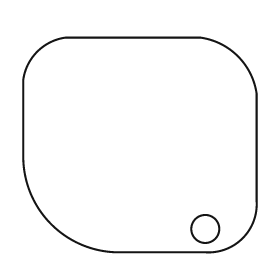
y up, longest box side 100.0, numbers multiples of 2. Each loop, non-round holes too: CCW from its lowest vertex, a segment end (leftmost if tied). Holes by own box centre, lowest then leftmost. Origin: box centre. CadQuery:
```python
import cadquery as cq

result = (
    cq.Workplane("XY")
    .moveTo(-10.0, -46.0)
    .lineTo(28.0, -46.0)
    .threePointArc((44.0, -40.0), (50.0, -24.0))
    .lineTo(50.0, 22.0)
    .threePointArc((42.0, 38.0), (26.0, 46.0))
    .lineTo(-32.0, 46.0)
    .threePointArc((-44.0, 40.0), (-50.0, 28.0))
    .lineTo(-50.0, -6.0)
    .threePointArc((-38.0, -34.0), (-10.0, -46.0))
    .close()
    .moveTo(28.0, -36.0)
    .circle(6.0)
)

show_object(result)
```